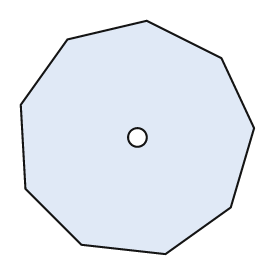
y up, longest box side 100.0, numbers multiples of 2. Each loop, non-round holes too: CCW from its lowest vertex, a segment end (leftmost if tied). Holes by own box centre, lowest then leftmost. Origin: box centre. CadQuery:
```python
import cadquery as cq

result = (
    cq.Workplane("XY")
    .moveTo(12.0, -50.0)
    .lineTo(40.0, -30.0)
    .lineTo(50.0, 4.0)
    .lineTo(36.0, 34.0)
    .lineTo(4.0, 50.0)
    .lineTo(-30.0, 42.0)
    .lineTo(-50.0, 14.0)
    .lineTo(-48.0, -22.0)
    .lineTo(-24.0, -46.0)
    .close()
    .moveTo(0.0, 0.0)
    .circle(4.0)
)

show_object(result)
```